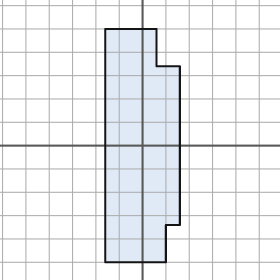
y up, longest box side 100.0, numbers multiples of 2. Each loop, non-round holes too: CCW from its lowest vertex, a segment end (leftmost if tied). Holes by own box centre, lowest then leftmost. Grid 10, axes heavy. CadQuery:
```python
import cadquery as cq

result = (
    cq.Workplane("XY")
    .moveTo(-16.0, -50.0)
    .lineTo(10.0, -50.0)
    .lineTo(10.0, -34.0)
    .lineTo(16.0, -34.0)
    .lineTo(16.0, 34.0)
    .lineTo(6.0, 34.0)
    .lineTo(6.0, 50.0)
    .lineTo(-16.0, 50.0)
    .close()
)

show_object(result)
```